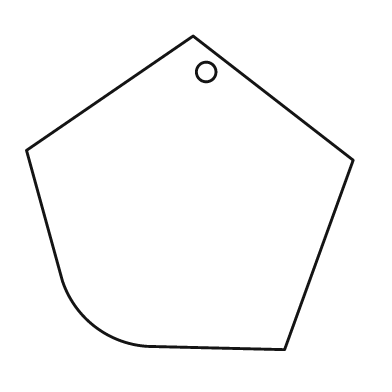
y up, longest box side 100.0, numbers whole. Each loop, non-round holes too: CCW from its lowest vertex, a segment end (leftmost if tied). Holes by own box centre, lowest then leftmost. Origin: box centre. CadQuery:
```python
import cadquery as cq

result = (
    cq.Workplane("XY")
    .moveTo(29.0, -48.0)
    .lineTo(50.0, 10.0)
    .lineTo(1.0, 48.0)
    .lineTo(-50.0, 13.0)
    .lineTo(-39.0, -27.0)
    .threePointArc((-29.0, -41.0), (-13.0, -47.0))
    .close()
    .moveTo(5.0, 37.0)
    .circle(3.0)
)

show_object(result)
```